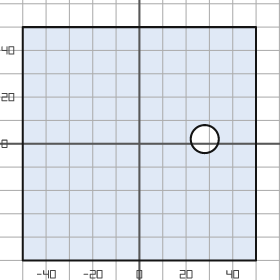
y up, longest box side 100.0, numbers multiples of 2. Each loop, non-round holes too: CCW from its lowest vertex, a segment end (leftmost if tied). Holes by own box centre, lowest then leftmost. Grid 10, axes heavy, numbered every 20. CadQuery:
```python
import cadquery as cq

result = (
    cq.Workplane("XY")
    .moveTo(-50.0, -50.0)
    .lineTo(50.0, -50.0)
    .lineTo(50.0, 50.0)
    .lineTo(-50.0, 50.0)
    .close()
    .moveTo(28.0, 2.0)
    .circle(6.0)
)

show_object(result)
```